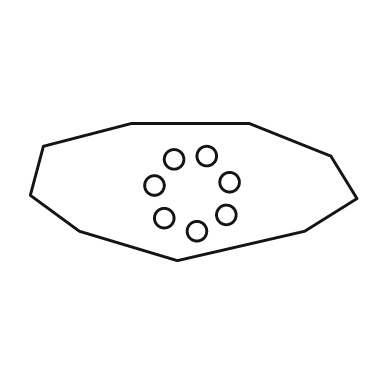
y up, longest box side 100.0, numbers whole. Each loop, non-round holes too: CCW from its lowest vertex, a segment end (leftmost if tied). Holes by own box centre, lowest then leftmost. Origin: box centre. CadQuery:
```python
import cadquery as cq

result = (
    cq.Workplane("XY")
    .moveTo(-5.0, -21.0)
    .lineTo(34.0, -12.0)
    .lineTo(50.0, -2.0)
    .lineTo(42.0, 11.0)
    .lineTo(17.0, 21.0)
    .lineTo(-19.0, 21.0)
    .lineTo(-46.0, 14.0)
    .lineTo(-50.0, -1.0)
    .lineTo(-35.0, -12.0)
    .close()
    .moveTo(1.0, -12.0)
    .circle(3.0)
    .moveTo(-9.0, -8.0)
    .circle(3.0)
    .moveTo(10.0, -7.0)
    .circle(3.0)
    .moveTo(-12.0, 2.0)
    .circle(3.0)
    .moveTo(11.0, 3.0)
    .circle(3.0)
    .moveTo(-6.0, 10.0)
    .circle(3.0)
    .moveTo(4.0, 11.0)
    .circle(3.0)
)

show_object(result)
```